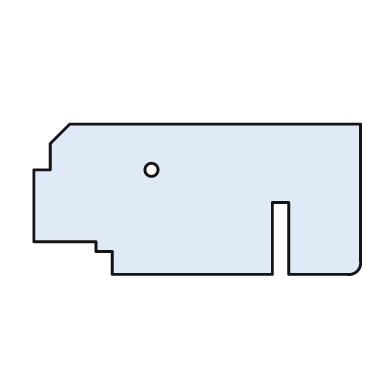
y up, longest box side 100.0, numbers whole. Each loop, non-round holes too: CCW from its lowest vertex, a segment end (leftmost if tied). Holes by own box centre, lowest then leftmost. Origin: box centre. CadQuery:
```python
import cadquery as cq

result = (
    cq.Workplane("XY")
    .moveTo(-26.0, -23.0)
    .lineTo(23.0, -23.0)
    .lineTo(23.0, -1.0)
    .lineTo(28.0, -1.0)
    .lineTo(28.0, -23.0)
    .lineTo(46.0, -23.0)
    .threePointArc((49.0, -22.0), (50.0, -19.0))
    .lineTo(50.0, 23.0)
    .lineTo(-39.0, 23.0)
    .lineTo(-45.0, 17.0)
    .lineTo(-45.0, 9.0)
    .lineTo(-50.0, 9.0)
    .lineTo(-50.0, -13.0)
    .lineTo(-31.0, -13.0)
    .lineTo(-31.0, -16.0)
    .lineTo(-26.0, -16.0)
    .close()
    .moveTo(-14.0, 9.0)
    .circle(2.0)
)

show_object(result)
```